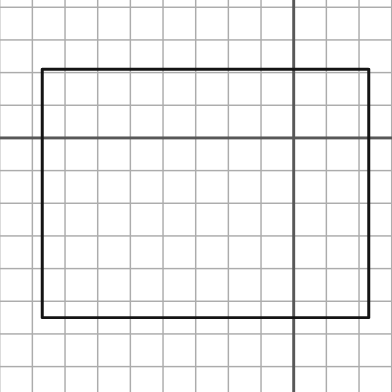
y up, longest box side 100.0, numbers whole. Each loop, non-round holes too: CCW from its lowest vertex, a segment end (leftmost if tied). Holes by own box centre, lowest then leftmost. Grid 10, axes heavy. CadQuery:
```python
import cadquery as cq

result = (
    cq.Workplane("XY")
    .moveTo(-77.0, -55.0)
    .lineTo(23.0, -55.0)
    .lineTo(23.0, 21.0)
    .lineTo(-77.0, 21.0)
    .close()
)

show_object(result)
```